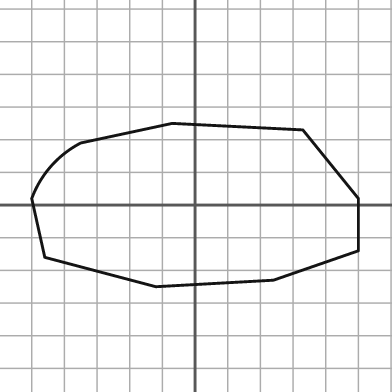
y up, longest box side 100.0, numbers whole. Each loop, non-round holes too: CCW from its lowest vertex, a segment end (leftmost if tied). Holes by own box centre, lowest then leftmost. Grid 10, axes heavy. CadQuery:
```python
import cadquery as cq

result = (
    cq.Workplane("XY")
    .moveTo(-12.0, -25.0)
    .lineTo(24.0, -23.0)
    .lineTo(50.0, -14.0)
    .lineTo(50.0, 2.0)
    .lineTo(33.0, 23.0)
    .lineTo(-7.0, 25.0)
    .lineTo(-35.0, 19.0)
    .threePointArc((-44.0, 12.0), (-50.0, 2.0))
    .lineTo(-46.0, -16.0)
    .close()
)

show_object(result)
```